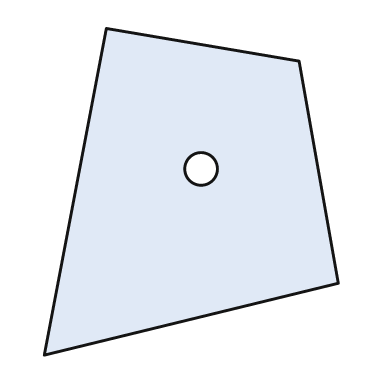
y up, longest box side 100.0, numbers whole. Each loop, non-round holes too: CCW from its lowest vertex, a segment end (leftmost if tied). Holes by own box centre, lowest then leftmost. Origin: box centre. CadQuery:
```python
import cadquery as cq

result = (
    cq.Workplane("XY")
    .moveTo(-45.0, -50.0)
    .lineTo(45.0, -28.0)
    .lineTo(33.0, 40.0)
    .lineTo(-26.0, 50.0)
    .close()
    .moveTo(3.0, 7.0)
    .circle(5.0)
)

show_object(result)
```